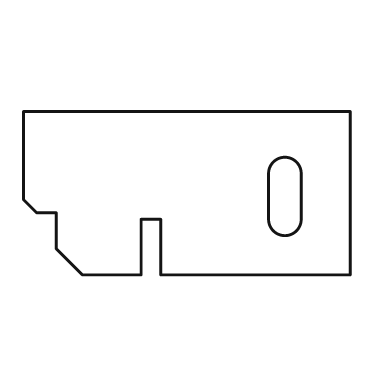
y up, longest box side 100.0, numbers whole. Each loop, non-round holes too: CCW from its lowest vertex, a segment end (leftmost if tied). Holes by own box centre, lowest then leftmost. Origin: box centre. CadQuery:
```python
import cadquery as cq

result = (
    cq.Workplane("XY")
    .moveTo(-32.0, -25.0)
    .lineTo(-14.0, -25.0)
    .lineTo(-14.0, -8.0)
    .lineTo(-8.0, -8.0)
    .lineTo(-8.0, -25.0)
    .lineTo(50.0, -25.0)
    .lineTo(50.0, 25.0)
    .lineTo(-50.0, 25.0)
    .lineTo(-50.0, -2.0)
    .lineTo(-46.0, -6.0)
    .lineTo(-40.0, -6.0)
    .lineTo(-40.0, -17.0)
    .close()
    .moveTo(25.0, -8.0)
    .threePointArc((30.0, -13.0), (35.0, -8.0))
    .lineTo(35.0, 6.0)
    .threePointArc((30.0, 11.0), (25.0, 6.0))
    .close()
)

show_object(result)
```